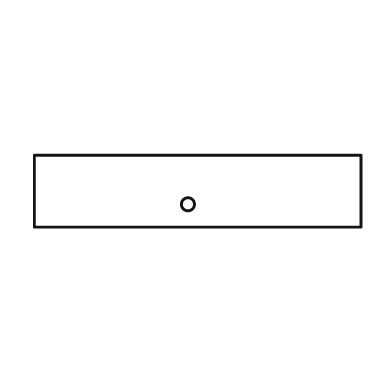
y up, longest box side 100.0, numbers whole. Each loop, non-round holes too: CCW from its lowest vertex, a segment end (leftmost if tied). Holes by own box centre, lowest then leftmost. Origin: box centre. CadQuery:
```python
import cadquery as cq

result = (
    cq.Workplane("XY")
    .moveTo(-50.0, -11.0)
    .lineTo(50.0, -11.0)
    .lineTo(50.0, 11.0)
    .lineTo(-50.0, 11.0)
    .close()
    .moveTo(-3.0, -4.0)
    .circle(2.0)
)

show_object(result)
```